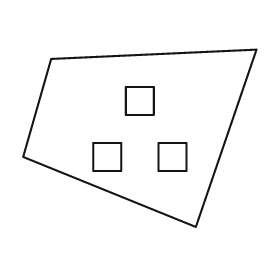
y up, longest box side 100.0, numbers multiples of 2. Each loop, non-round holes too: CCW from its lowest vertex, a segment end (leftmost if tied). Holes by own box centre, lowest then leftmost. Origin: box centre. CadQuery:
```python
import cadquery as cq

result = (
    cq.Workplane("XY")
    .moveTo(24.0, -38.0)
    .lineTo(50.0, 38.0)
    .lineTo(-38.0, 34.0)
    .lineTo(-50.0, -8.0)
    .close()
    .moveTo(-20.0, -14.0)
    .lineTo(-8.0, -14.0)
    .lineTo(-8.0, -2.0)
    .lineTo(-20.0, -2.0)
    .close()
    .moveTo(8.0, -14.0)
    .lineTo(20.0, -14.0)
    .lineTo(20.0, -2.0)
    .lineTo(8.0, -2.0)
    .close()
    .moveTo(-6.0, 10.0)
    .lineTo(6.0, 10.0)
    .lineTo(6.0, 22.0)
    .lineTo(-6.0, 22.0)
    .close()
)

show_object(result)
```